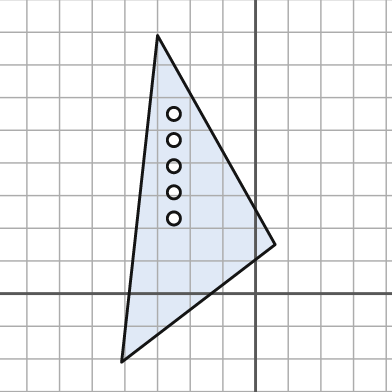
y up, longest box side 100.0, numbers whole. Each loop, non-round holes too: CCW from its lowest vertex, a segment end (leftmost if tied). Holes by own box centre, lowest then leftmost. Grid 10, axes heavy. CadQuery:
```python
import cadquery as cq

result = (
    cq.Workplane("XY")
    .moveTo(-41.0, -21.0)
    .lineTo(6.0, 15.0)
    .lineTo(-30.0, 79.0)
    .close()
    .moveTo(-25.0, 23.0)
    .circle(2.0)
    .moveTo(-25.0, 31.0)
    .circle(2.0)
    .moveTo(-25.0, 39.0)
    .circle(2.0)
    .moveTo(-25.0, 47.0)
    .circle(2.0)
    .moveTo(-25.0, 55.0)
    .circle(2.0)
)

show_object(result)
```